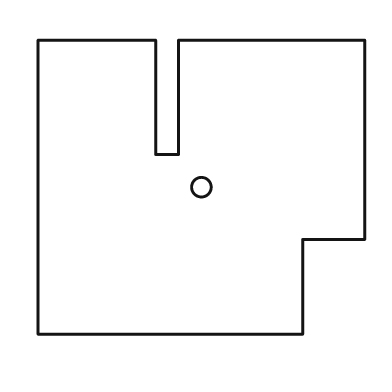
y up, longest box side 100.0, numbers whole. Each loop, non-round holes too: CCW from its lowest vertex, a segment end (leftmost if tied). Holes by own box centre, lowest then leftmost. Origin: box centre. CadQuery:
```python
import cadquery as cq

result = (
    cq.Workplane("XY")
    .moveTo(-50.0, -45.0)
    .lineTo(31.0, -45.0)
    .lineTo(31.0, -16.0)
    .lineTo(50.0, -16.0)
    .lineTo(50.0, 45.0)
    .lineTo(-7.0, 45.0)
    .lineTo(-7.0, 10.0)
    .lineTo(-14.0, 10.0)
    .lineTo(-14.0, 45.0)
    .lineTo(-50.0, 45.0)
    .close()
    .moveTo(0.0, 0.0)
    .circle(3.0)
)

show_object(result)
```